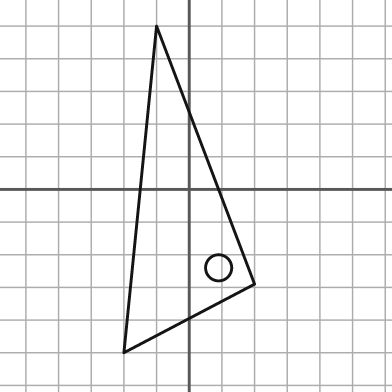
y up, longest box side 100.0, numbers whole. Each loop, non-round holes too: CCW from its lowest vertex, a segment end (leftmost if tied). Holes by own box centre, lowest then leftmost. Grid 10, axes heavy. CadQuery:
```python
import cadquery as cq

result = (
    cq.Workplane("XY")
    .moveTo(-20.0, -50.0)
    .lineTo(20.0, -29.0)
    .lineTo(-10.0, 50.0)
    .close()
    .moveTo(9.0, -24.0)
    .circle(4.0)
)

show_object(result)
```